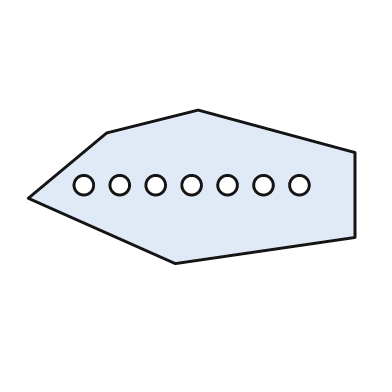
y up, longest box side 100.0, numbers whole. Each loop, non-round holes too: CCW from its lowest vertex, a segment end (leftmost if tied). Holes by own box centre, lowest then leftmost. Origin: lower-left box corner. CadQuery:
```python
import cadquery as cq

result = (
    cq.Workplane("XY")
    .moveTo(45.0, 0.0)
    .lineTo(100.0, 8.0)
    .lineTo(100.0, 34.0)
    .lineTo(52.0, 47.0)
    .lineTo(24.0, 40.0)
    .lineTo(0.0, 20.0)
    .close()
    .moveTo(17.0, 24.0)
    .circle(3.0)
    .moveTo(28.0, 24.0)
    .circle(3.0)
    .moveTo(39.0, 24.0)
    .circle(3.0)
    .moveTo(50.0, 24.0)
    .circle(3.0)
    .moveTo(61.0, 24.0)
    .circle(3.0)
    .moveTo(72.0, 24.0)
    .circle(3.0)
    .moveTo(83.0, 24.0)
    .circle(3.0)
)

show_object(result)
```